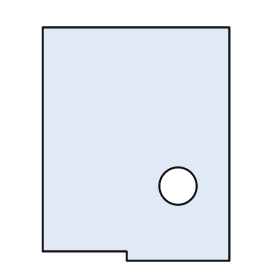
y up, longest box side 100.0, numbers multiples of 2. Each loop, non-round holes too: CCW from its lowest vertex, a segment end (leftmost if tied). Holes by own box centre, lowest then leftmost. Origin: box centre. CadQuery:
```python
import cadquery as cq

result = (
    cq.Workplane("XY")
    .moveTo(-4.0, -50.0)
    .lineTo(40.0, -50.0)
    .lineTo(40.0, 50.0)
    .lineTo(-40.0, 50.0)
    .lineTo(-40.0, -46.0)
    .lineTo(-4.0, -46.0)
    .close()
    .moveTo(18.0, -18.0)
    .circle(8.0)
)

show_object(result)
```